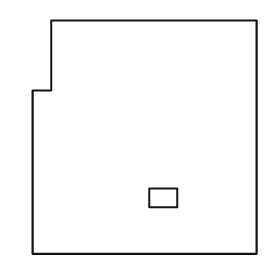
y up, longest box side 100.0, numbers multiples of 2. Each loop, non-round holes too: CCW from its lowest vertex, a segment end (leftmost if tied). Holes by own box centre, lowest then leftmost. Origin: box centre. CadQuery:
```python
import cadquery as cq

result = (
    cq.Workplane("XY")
    .moveTo(-48.0, -50.0)
    .lineTo(48.0, -50.0)
    .lineTo(48.0, 50.0)
    .lineTo(-40.0, 50.0)
    .lineTo(-40.0, 20.0)
    .lineTo(-48.0, 20.0)
    .close()
    .moveTo(2.0, -30.0)
    .lineTo(14.0, -30.0)
    .lineTo(14.0, -22.0)
    .lineTo(2.0, -22.0)
    .close()
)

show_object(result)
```